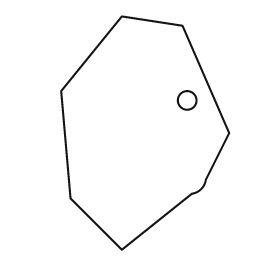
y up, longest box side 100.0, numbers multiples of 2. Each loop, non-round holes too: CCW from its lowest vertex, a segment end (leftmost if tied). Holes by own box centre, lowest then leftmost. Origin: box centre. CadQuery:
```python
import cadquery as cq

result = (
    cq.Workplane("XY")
    .moveTo(-10.0, -50.0)
    .lineTo(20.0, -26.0)
    .threePointArc((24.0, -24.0), (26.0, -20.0))
    .lineTo(36.0, 0.0)
    .lineTo(16.0, 46.0)
    .lineTo(-10.0, 50.0)
    .lineTo(-36.0, 18.0)
    .lineTo(-32.0, -28.0)
    .close()
    .moveTo(18.0, 14.0)
    .circle(4.0)
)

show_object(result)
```